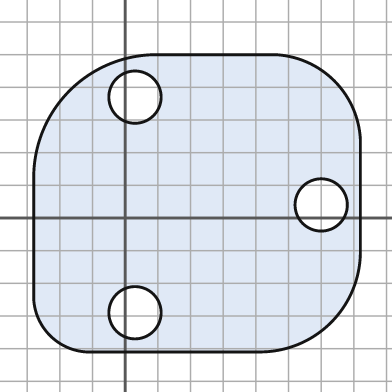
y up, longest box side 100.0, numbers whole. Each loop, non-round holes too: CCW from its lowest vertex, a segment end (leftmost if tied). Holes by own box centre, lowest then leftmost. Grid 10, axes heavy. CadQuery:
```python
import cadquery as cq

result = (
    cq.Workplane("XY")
    .moveTo(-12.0, -41.0)
    .lineTo(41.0, -41.0)
    .threePointArc((63.0, -32.0), (72.0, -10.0))
    .lineTo(72.0, 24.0)
    .threePointArc((64.0, 42.0), (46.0, 50.0))
    .lineTo(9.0, 50.0)
    .threePointArc((-17.0, 39.0), (-28.0, 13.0))
    .lineTo(-28.0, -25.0)
    .threePointArc((-23.0, -36.0), (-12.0, -41.0))
    .close()
    .moveTo(3.0, -29.0)
    .circle(8.0)
    .moveTo(60.0, 4.0)
    .circle(8.0)
    .moveTo(3.0, 37.0)
    .circle(8.0)
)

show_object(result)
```